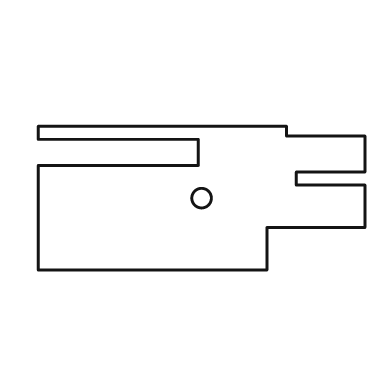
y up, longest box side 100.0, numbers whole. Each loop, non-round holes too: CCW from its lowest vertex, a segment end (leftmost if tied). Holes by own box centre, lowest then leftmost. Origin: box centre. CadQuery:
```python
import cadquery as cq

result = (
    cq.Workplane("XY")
    .moveTo(-50.0, -22.0)
    .lineTo(20.0, -22.0)
    .lineTo(20.0, -9.0)
    .lineTo(50.0, -9.0)
    .lineTo(50.0, 4.0)
    .lineTo(29.0, 4.0)
    .lineTo(29.0, 8.0)
    .lineTo(50.0, 8.0)
    .lineTo(50.0, 19.0)
    .lineTo(26.0, 19.0)
    .lineTo(26.0, 22.0)
    .lineTo(-50.0, 22.0)
    .lineTo(-50.0, 18.0)
    .lineTo(-1.0, 18.0)
    .lineTo(-1.0, 10.0)
    .lineTo(-50.0, 10.0)
    .close()
    .moveTo(0.0, 0.0)
    .circle(3.0)
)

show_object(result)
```